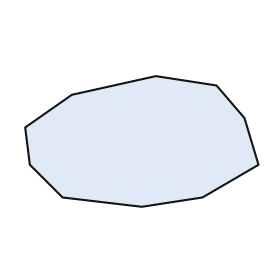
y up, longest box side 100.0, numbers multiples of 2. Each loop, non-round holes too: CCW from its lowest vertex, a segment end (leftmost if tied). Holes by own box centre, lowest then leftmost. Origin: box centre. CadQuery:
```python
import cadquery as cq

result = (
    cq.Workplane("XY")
    .moveTo(0.0, -28.0)
    .lineTo(26.0, -24.0)
    .lineTo(50.0, -10.0)
    .lineTo(44.0, 10.0)
    .lineTo(32.0, 24.0)
    .lineTo(6.0, 28.0)
    .lineTo(-30.0, 20.0)
    .lineTo(-50.0, 6.0)
    .lineTo(-48.0, -10.0)
    .lineTo(-34.0, -24.0)
    .close()
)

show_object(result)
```